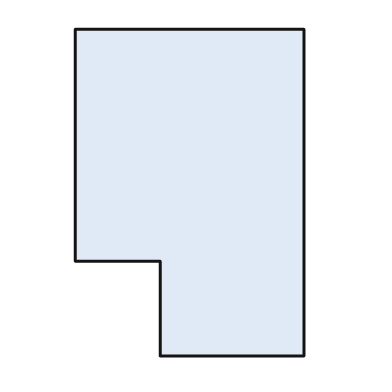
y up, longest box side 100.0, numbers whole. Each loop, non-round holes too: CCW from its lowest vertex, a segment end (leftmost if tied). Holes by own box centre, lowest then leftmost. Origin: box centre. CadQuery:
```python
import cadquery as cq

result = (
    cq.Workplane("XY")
    .moveTo(-9.0, -50.0)
    .lineTo(35.0, -50.0)
    .lineTo(35.0, 50.0)
    .lineTo(-35.0, 50.0)
    .lineTo(-35.0, -21.0)
    .lineTo(-9.0, -21.0)
    .close()
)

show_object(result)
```